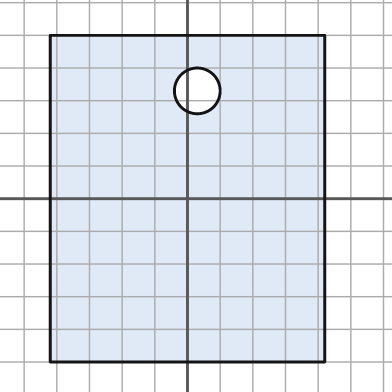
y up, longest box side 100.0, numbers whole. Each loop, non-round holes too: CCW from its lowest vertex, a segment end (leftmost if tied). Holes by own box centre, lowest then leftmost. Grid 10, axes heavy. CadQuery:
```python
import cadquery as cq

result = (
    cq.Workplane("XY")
    .moveTo(-42.0, -50.0)
    .lineTo(42.0, -50.0)
    .lineTo(42.0, 50.0)
    .lineTo(-42.0, 50.0)
    .close()
    .moveTo(3.0, 33.0)
    .circle(7.0)
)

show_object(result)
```